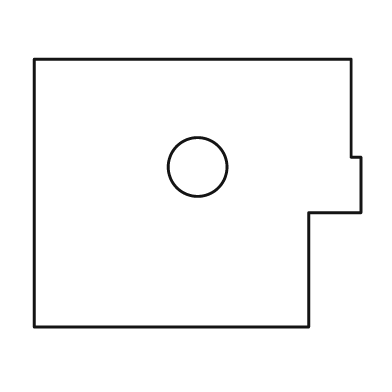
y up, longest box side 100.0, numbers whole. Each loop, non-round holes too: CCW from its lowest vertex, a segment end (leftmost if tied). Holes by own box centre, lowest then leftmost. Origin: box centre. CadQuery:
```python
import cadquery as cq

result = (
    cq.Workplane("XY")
    .moveTo(-50.0, -41.0)
    .lineTo(34.0, -41.0)
    .lineTo(34.0, -6.0)
    .lineTo(50.0, -6.0)
    .lineTo(50.0, 11.0)
    .lineTo(47.0, 11.0)
    .lineTo(47.0, 41.0)
    .lineTo(-50.0, 41.0)
    .close()
    .moveTo(0.0, 8.0)
    .circle(9.0)
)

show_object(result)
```